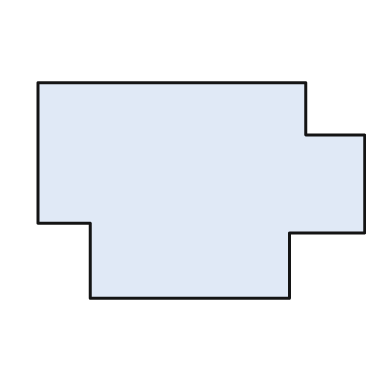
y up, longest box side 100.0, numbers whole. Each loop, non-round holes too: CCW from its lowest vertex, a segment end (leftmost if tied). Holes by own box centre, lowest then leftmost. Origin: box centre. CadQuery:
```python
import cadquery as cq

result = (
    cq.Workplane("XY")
    .moveTo(-34.0, -33.0)
    .lineTo(27.0, -33.0)
    .lineTo(27.0, -13.0)
    .lineTo(50.0, -13.0)
    .lineTo(50.0, 17.0)
    .lineTo(32.0, 17.0)
    .lineTo(32.0, 33.0)
    .lineTo(-50.0, 33.0)
    .lineTo(-50.0, -10.0)
    .lineTo(-34.0, -10.0)
    .close()
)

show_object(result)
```